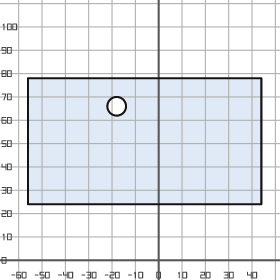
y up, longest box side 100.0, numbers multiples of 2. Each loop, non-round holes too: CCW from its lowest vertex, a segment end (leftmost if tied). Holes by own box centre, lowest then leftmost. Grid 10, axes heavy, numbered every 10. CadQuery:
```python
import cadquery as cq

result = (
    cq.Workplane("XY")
    .moveTo(-56.0, 24.0)
    .lineTo(44.0, 24.0)
    .lineTo(44.0, 78.0)
    .lineTo(-56.0, 78.0)
    .close()
    .moveTo(-18.0, 66.0)
    .circle(4.0)
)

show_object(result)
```